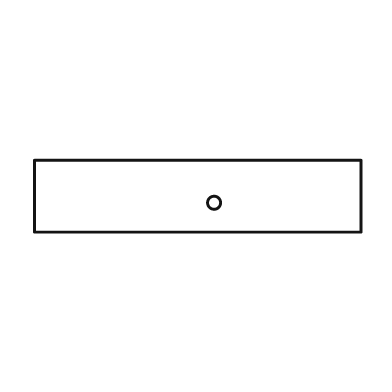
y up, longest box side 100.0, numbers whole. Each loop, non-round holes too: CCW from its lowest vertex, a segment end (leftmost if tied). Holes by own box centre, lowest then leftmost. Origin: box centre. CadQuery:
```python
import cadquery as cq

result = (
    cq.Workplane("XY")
    .moveTo(-50.0, -11.0)
    .lineTo(50.0, -11.0)
    .lineTo(50.0, 11.0)
    .lineTo(-50.0, 11.0)
    .close()
    .moveTo(5.0, -2.0)
    .circle(2.0)
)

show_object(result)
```